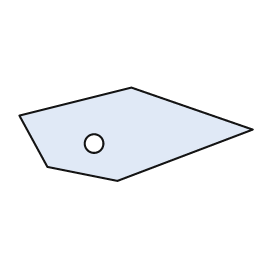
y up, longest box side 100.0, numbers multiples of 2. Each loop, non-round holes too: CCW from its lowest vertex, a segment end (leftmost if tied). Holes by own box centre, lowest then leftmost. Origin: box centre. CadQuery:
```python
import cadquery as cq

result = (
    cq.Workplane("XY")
    .moveTo(-8.0, -20.0)
    .lineTo(50.0, 2.0)
    .lineTo(-2.0, 20.0)
    .lineTo(-50.0, 8.0)
    .lineTo(-38.0, -14.0)
    .close()
    .moveTo(-18.0, -4.0)
    .circle(4.0)
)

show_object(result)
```